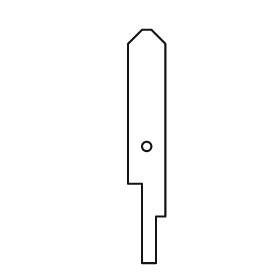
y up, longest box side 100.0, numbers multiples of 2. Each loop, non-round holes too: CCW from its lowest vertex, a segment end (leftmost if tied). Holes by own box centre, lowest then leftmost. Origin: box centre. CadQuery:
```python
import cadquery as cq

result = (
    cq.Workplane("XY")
    .moveTo(-2.0, -50.0)
    .lineTo(4.0, -50.0)
    .lineTo(4.0, -30.0)
    .lineTo(8.0, -30.0)
    .lineTo(8.0, 44.0)
    .lineTo(2.0, 50.0)
    .lineTo(-2.0, 50.0)
    .lineTo(-8.0, 44.0)
    .lineTo(-8.0, -16.0)
    .lineTo(-2.0, -16.0)
    .close()
    .moveTo(0.0, 0.0)
    .circle(2.0)
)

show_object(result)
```